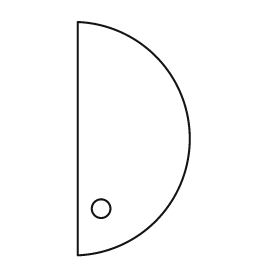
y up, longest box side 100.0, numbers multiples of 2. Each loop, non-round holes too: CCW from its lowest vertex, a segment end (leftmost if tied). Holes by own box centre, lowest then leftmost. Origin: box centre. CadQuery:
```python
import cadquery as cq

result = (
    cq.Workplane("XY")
    .moveTo(-24.0, -50.0)
    .threePointArc((24.0, 0.0), (-24.0, 50.0))
    .close()
    .moveTo(-14.0, -30.0)
    .circle(4.0)
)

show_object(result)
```